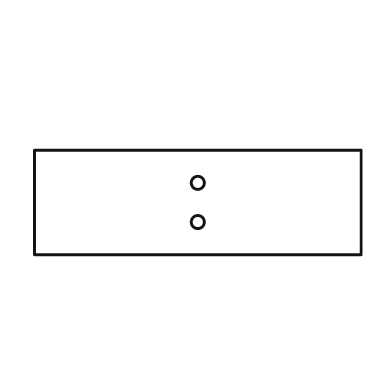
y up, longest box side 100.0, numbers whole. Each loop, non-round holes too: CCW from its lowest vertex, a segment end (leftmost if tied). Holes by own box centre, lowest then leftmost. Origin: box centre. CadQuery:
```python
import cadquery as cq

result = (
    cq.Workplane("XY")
    .moveTo(-50.0, -16.0)
    .lineTo(50.0, -16.0)
    .lineTo(50.0, 16.0)
    .lineTo(-50.0, 16.0)
    .close()
    .moveTo(0.0, -6.0)
    .circle(2.0)
    .moveTo(0.0, 6.0)
    .circle(2.0)
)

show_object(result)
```